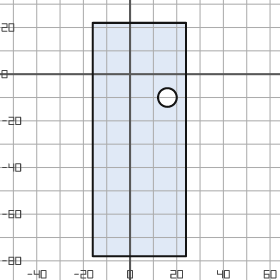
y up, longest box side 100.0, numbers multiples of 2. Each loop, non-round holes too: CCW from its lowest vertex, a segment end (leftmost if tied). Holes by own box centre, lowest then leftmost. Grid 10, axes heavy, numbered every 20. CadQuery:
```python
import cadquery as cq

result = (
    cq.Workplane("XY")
    .moveTo(-16.0, -78.0)
    .lineTo(24.0, -78.0)
    .lineTo(24.0, 22.0)
    .lineTo(-16.0, 22.0)
    .close()
    .moveTo(16.0, -10.0)
    .circle(4.0)
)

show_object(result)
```